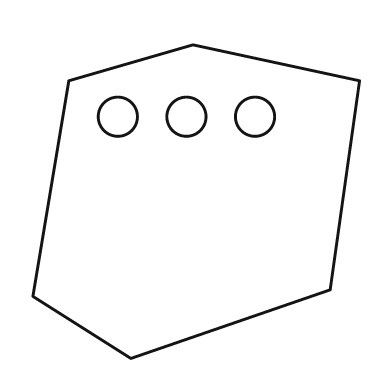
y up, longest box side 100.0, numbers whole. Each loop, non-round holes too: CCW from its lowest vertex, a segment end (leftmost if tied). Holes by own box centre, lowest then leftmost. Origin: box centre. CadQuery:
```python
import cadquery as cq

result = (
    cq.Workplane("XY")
    .moveTo(-20.0, -48.0)
    .lineTo(41.0, -27.0)
    .lineTo(50.0, 37.0)
    .lineTo(-1.0, 48.0)
    .lineTo(-39.0, 37.0)
    .lineTo(-50.0, -29.0)
    .close()
    .moveTo(-24.0, 26.0)
    .circle(6.0)
    .moveTo(-3.0, 26.0)
    .circle(6.0)
    .moveTo(18.0, 26.0)
    .circle(6.0)
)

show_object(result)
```